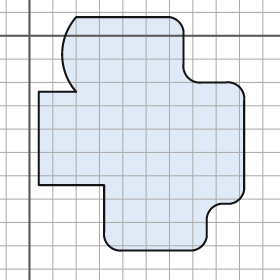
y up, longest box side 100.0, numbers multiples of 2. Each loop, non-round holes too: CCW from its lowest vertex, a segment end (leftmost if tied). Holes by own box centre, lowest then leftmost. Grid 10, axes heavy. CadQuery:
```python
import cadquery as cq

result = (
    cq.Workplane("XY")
    .moveTo(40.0, -92.0)
    .lineTo(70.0, -92.0)
    .threePointArc((74.0, -90.0), (76.0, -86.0))
    .lineTo(76.0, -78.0)
    .threePointArc((78.0, -74.0), (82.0, -72.0))
    .lineTo(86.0, -72.0)
    .threePointArc((90.0, -70.0), (92.0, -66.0))
    .lineTo(92.0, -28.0)
    .threePointArc((90.0, -22.0), (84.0, -20.0))
    .lineTo(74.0, -20.0)
    .threePointArc((68.0, -18.0), (66.0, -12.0))
    .lineTo(66.0, 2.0)
    .threePointArc((64.0, 6.0), (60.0, 8.0))
    .lineTo(20.0, 8.0)
    .threePointArc((14.0, -8.0), (20.0, -24.0))
    .lineTo(4.0, -24.0)
    .lineTo(4.0, -64.0)
    .lineTo(32.0, -64.0)
    .lineTo(32.0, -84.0)
    .threePointArc((34.0, -90.0), (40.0, -92.0))
    .close()
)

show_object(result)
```